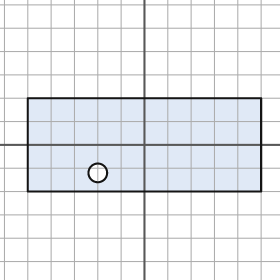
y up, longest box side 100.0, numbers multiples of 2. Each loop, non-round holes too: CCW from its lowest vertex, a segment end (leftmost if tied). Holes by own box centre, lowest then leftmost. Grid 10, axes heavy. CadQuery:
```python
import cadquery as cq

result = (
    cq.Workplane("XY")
    .moveTo(-50.0, -20.0)
    .lineTo(50.0, -20.0)
    .lineTo(50.0, 20.0)
    .lineTo(-50.0, 20.0)
    .close()
    .moveTo(-20.0, -12.0)
    .circle(4.0)
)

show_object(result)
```